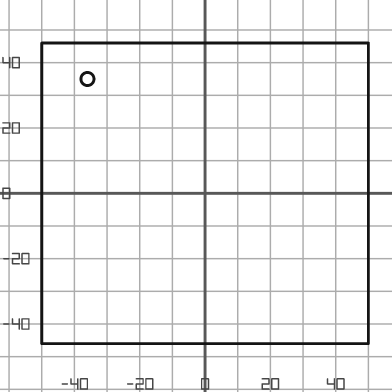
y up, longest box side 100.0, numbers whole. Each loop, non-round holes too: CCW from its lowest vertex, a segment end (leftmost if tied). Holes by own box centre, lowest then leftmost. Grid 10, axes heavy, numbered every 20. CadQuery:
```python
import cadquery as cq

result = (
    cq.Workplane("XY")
    .moveTo(-50.0, -46.0)
    .lineTo(50.0, -46.0)
    .lineTo(50.0, 46.0)
    .lineTo(-50.0, 46.0)
    .close()
    .moveTo(-36.0, 35.0)
    .circle(2.0)
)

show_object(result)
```